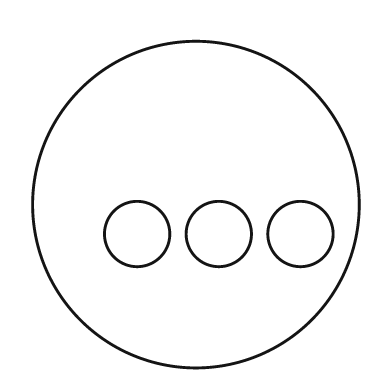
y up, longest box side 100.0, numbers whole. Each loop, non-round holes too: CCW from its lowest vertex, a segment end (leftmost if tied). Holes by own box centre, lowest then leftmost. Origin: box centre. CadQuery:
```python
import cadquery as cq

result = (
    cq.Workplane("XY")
    .moveTo(0.0, 0.0)
    .circle(50.0)
    .moveTo(-18.0, -9.0)
    .circle(10.0)
    .moveTo(7.0, -9.0)
    .circle(10.0)
    .moveTo(32.0, -9.0)
    .circle(10.0)
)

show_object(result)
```